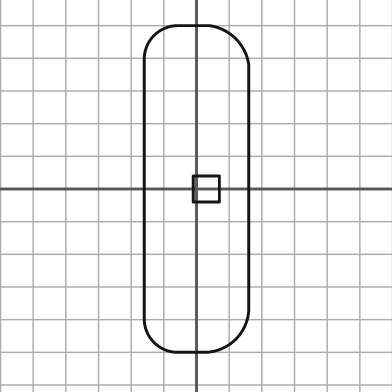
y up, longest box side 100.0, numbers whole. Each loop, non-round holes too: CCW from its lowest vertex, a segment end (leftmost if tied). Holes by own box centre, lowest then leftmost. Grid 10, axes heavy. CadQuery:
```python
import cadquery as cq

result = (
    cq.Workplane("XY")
    .moveTo(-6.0, -50.0)
    .lineTo(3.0, -50.0)
    .threePointArc((12.0, -46.0), (16.0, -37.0))
    .lineTo(16.0, 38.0)
    .threePointArc((12.0, 46.0), (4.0, 50.0))
    .lineTo(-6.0, 50.0)
    .threePointArc((-13.0, 47.0), (-16.0, 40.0))
    .lineTo(-16.0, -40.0)
    .threePointArc((-13.0, -47.0), (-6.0, -50.0))
    .close()
    .moveTo(-1.0, -4.0)
    .lineTo(7.0, -4.0)
    .lineTo(7.0, 4.0)
    .lineTo(-1.0, 4.0)
    .close()
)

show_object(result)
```